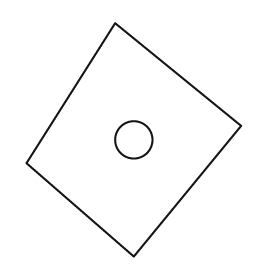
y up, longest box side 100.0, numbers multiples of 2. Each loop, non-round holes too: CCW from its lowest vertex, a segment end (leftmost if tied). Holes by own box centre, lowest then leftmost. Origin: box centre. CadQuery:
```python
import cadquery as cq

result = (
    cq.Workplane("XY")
    .moveTo(0.0, -50.0)
    .lineTo(46.0, 6.0)
    .lineTo(-8.0, 50.0)
    .lineTo(-46.0, -10.0)
    .close()
    .moveTo(0.0, 0.0)
    .circle(8.0)
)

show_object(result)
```